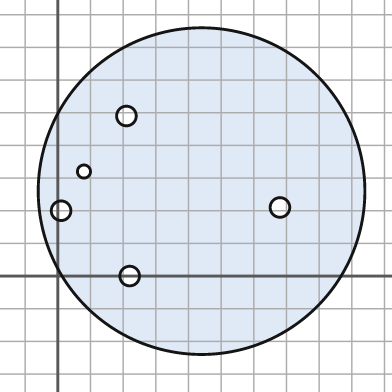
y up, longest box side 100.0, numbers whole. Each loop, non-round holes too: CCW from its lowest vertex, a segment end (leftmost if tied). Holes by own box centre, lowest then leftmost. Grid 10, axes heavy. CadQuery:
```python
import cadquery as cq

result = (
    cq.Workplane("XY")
    .moveTo(44.0, 26.0)
    .circle(50.0)
    .moveTo(22.0, 0.0)
    .circle(3.0)
    .moveTo(1.0, 20.0)
    .circle(3.0)
    .moveTo(68.0, 21.0)
    .circle(3.0)
    .moveTo(8.0, 32.0)
    .circle(2.0)
    .moveTo(21.0, 49.0)
    .circle(3.0)
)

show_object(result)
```